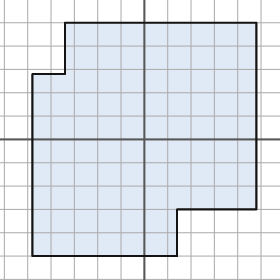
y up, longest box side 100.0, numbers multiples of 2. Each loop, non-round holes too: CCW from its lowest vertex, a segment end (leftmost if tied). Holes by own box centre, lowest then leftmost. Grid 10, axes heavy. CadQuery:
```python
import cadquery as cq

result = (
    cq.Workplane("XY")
    .moveTo(-48.0, -50.0)
    .lineTo(14.0, -50.0)
    .lineTo(14.0, -30.0)
    .lineTo(48.0, -30.0)
    .lineTo(48.0, 50.0)
    .lineTo(-34.0, 50.0)
    .lineTo(-34.0, 28.0)
    .lineTo(-48.0, 28.0)
    .close()
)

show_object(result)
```